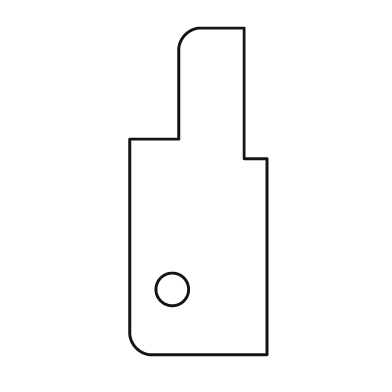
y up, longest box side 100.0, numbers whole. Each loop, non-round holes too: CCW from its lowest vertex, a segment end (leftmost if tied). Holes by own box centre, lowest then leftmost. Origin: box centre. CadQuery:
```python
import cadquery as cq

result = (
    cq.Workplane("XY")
    .moveTo(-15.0, -50.0)
    .lineTo(21.0, -50.0)
    .lineTo(21.0, 10.0)
    .lineTo(14.0, 10.0)
    .lineTo(14.0, 50.0)
    .lineTo(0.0, 50.0)
    .threePointArc((-4.0, 48.0), (-6.0, 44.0))
    .lineTo(-6.0, 16.0)
    .lineTo(-21.0, 16.0)
    .lineTo(-21.0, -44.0)
    .threePointArc((-19.0, -48.0), (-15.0, -50.0))
    .close()
    .moveTo(-8.0, -30.0)
    .circle(5.0)
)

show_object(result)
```